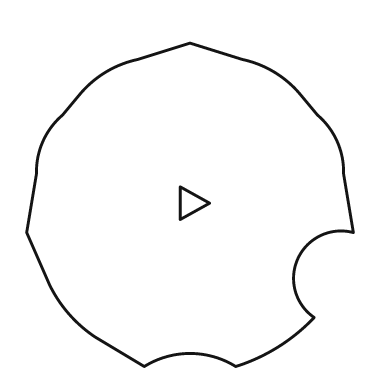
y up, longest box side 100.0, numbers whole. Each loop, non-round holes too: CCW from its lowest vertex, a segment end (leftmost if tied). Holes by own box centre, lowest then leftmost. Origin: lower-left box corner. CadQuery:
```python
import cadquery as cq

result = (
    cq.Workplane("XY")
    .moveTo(36.0, 0.0)
    .threePointArc((50.0, 4.0), (64.0, 0.0))
    .threePointArc((77.0, 6.0), (88.0, 15.0))
    .threePointArc((83.0, 33.0), (100.0, 41.0))
    .lineTo(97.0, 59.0)
    .threePointArc((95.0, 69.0), (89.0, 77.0))
    .lineTo(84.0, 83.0)
    .threePointArc((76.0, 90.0), (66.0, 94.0))
    .lineTo(50.0, 99.0)
    .lineTo(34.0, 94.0)
    .threePointArc((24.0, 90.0), (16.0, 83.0))
    .lineTo(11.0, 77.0)
    .threePointArc((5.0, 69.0), (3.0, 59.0))
    .lineTo(0.0, 41.0)
    .lineTo(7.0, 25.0)
    .threePointArc((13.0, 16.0), (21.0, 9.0))
    .close()
    .moveTo(47.0, 45.0)
    .lineTo(56.0, 50.0)
    .lineTo(47.0, 55.0)
    .close()
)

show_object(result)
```